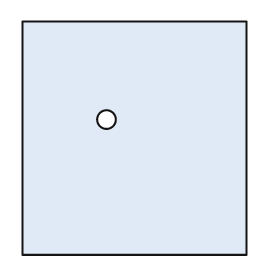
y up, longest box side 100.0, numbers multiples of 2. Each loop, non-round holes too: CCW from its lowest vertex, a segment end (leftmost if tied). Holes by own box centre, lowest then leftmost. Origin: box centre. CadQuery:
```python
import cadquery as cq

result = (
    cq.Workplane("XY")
    .moveTo(-48.0, -50.0)
    .lineTo(48.0, -50.0)
    .lineTo(48.0, 50.0)
    .lineTo(-48.0, 50.0)
    .close()
    .moveTo(-12.0, 8.0)
    .circle(4.0)
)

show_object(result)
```